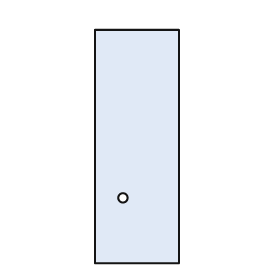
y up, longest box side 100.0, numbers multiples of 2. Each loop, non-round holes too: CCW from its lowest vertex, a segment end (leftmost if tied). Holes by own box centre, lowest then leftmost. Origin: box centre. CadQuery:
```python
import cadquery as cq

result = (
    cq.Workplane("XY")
    .moveTo(-18.0, -50.0)
    .lineTo(18.0, -50.0)
    .lineTo(18.0, 50.0)
    .lineTo(-18.0, 50.0)
    .close()
    .moveTo(-6.0, -22.0)
    .circle(2.0)
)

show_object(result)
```